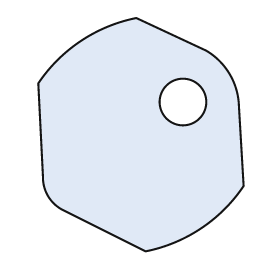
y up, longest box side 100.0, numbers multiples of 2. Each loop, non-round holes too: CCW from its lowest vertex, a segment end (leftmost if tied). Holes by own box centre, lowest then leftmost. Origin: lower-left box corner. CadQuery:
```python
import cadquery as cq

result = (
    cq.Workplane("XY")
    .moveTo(46.0, 0.0)
    .threePointArc((70.0, 10.0), (88.0, 28.0))
    .lineTo(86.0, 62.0)
    .threePointArc((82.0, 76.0), (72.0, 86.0))
    .lineTo(42.0, 100.0)
    .threePointArc((18.0, 90.0), (0.0, 72.0))
    .lineTo(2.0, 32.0)
    .threePointArc((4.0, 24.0), (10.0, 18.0))
    .close()
    .moveTo(62.0, 64.0)
    .circle(10.0)
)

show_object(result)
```